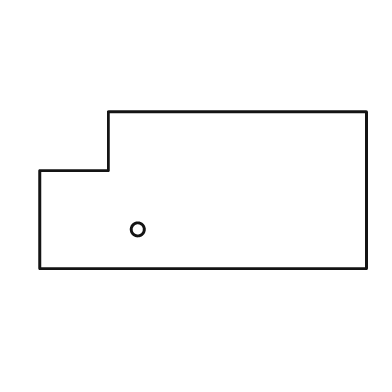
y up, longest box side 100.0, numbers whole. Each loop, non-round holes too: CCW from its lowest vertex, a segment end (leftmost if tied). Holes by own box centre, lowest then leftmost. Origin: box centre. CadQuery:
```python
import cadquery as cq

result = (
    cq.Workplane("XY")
    .moveTo(-50.0, -24.0)
    .lineTo(50.0, -24.0)
    .lineTo(50.0, 24.0)
    .lineTo(-29.0, 24.0)
    .lineTo(-29.0, 6.0)
    .lineTo(-50.0, 6.0)
    .close()
    .moveTo(-20.0, -12.0)
    .circle(2.0)
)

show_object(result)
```